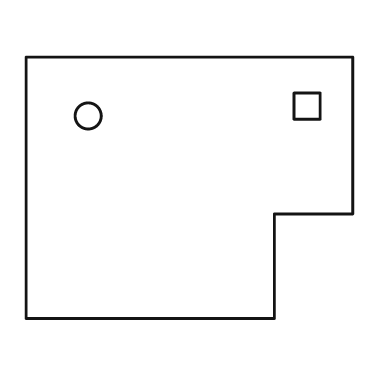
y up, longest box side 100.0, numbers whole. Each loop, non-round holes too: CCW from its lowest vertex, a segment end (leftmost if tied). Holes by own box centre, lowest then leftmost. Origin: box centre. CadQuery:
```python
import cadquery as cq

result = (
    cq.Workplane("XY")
    .moveTo(-50.0, -40.0)
    .lineTo(26.0, -40.0)
    .lineTo(26.0, -8.0)
    .lineTo(50.0, -8.0)
    .lineTo(50.0, 40.0)
    .lineTo(-50.0, 40.0)
    .close()
    .moveTo(-31.0, 22.0)
    .circle(4.0)
    .moveTo(32.0, 21.0)
    .lineTo(40.0, 21.0)
    .lineTo(40.0, 29.0)
    .lineTo(32.0, 29.0)
    .close()
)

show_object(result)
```